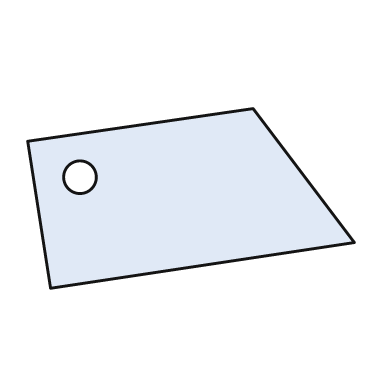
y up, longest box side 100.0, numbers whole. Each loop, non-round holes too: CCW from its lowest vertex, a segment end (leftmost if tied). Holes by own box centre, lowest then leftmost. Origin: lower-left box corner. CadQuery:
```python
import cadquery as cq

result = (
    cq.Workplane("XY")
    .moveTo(7.0, 0.0)
    .lineTo(100.0, 14.0)
    .lineTo(69.0, 55.0)
    .lineTo(0.0, 45.0)
    .close()
    .moveTo(16.0, 34.0)
    .circle(5.0)
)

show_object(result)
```